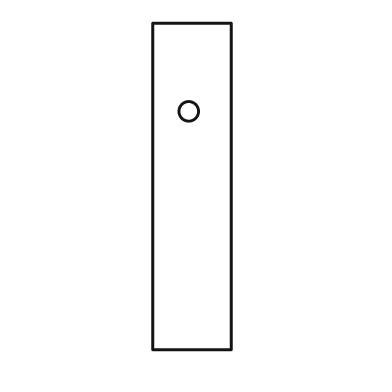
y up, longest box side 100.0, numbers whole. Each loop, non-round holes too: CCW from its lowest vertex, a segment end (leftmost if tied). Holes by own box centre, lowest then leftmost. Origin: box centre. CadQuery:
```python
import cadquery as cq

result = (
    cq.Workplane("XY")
    .moveTo(-12.0, -50.0)
    .lineTo(12.0, -50.0)
    .lineTo(12.0, 50.0)
    .lineTo(-12.0, 50.0)
    .close()
    .moveTo(-1.0, 23.0)
    .circle(3.0)
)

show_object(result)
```